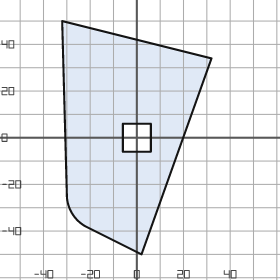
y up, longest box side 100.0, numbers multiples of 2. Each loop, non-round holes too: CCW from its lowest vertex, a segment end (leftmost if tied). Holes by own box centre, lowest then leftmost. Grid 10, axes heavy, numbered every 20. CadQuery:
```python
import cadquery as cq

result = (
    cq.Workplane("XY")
    .moveTo(2.0, -50.0)
    .lineTo(32.0, 34.0)
    .lineTo(-32.0, 50.0)
    .lineTo(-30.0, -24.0)
    .threePointArc((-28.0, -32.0), (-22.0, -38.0))
    .close()
    .moveTo(-6.0, -6.0)
    .lineTo(6.0, -6.0)
    .lineTo(6.0, 6.0)
    .lineTo(-6.0, 6.0)
    .close()
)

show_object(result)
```